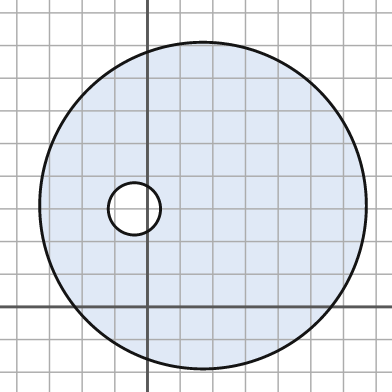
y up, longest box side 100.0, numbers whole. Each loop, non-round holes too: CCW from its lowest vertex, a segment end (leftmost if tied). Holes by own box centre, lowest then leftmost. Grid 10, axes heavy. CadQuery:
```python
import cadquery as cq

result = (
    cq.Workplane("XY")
    .moveTo(17.0, 31.0)
    .circle(50.0)
    .moveTo(-4.0, 30.0)
    .circle(8.0)
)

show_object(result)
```